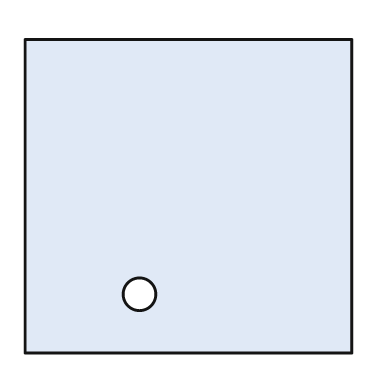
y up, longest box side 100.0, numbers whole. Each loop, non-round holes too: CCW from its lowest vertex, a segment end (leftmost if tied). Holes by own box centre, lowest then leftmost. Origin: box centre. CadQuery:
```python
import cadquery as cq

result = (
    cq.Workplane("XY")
    .moveTo(-50.0, -48.0)
    .lineTo(50.0, -48.0)
    .lineTo(50.0, 48.0)
    .lineTo(-50.0, 48.0)
    .close()
    .moveTo(-15.0, -30.0)
    .circle(5.0)
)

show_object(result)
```